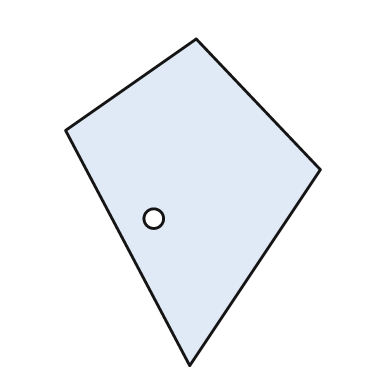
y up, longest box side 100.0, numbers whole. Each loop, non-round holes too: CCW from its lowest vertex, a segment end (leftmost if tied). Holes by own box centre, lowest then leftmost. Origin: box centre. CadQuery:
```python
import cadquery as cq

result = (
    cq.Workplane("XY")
    .moveTo(-1.0, -50.0)
    .lineTo(39.0, 10.0)
    .lineTo(1.0, 50.0)
    .lineTo(-39.0, 22.0)
    .close()
    .moveTo(-12.0, -5.0)
    .circle(3.0)
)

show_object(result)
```